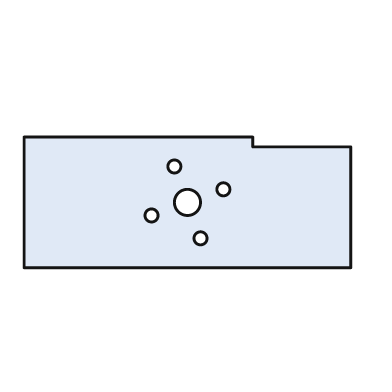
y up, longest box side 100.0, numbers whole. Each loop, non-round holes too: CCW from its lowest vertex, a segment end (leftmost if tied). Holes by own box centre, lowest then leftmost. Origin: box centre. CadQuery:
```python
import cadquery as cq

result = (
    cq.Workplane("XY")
    .moveTo(-50.0, -20.0)
    .lineTo(50.0, -20.0)
    .lineTo(50.0, 17.0)
    .lineTo(20.0, 17.0)
    .lineTo(20.0, 20.0)
    .lineTo(-50.0, 20.0)
    .close()
    .moveTo(4.0, -11.0)
    .circle(2.0)
    .moveTo(-11.0, -4.0)
    .circle(2.0)
    .moveTo(0.0, 0.0)
    .circle(4.0)
    .moveTo(11.0, 4.0)
    .circle(2.0)
    .moveTo(-4.0, 11.0)
    .circle(2.0)
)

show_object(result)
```